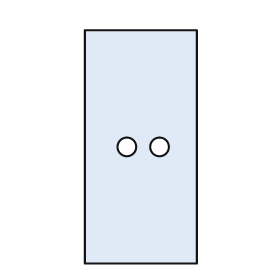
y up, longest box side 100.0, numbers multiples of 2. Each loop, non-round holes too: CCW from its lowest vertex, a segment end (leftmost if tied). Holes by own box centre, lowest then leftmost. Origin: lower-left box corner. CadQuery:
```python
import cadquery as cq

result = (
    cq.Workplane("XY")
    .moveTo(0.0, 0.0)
    .lineTo(48.0, 0.0)
    .lineTo(48.0, 100.0)
    .lineTo(0.0, 100.0)
    .close()
    .moveTo(18.0, 50.0)
    .circle(4.0)
    .moveTo(32.0, 50.0)
    .circle(4.0)
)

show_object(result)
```